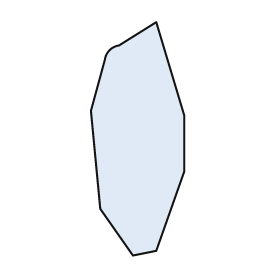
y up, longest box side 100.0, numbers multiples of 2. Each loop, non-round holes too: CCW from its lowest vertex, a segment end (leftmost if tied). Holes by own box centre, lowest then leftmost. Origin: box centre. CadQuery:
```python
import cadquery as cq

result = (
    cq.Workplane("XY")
    .moveTo(-2.0, -50.0)
    .lineTo(8.0, -48.0)
    .lineTo(20.0, -14.0)
    .lineTo(20.0, 10.0)
    .lineTo(8.0, 50.0)
    .lineTo(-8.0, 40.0)
    .threePointArc((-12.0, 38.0), (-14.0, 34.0))
    .lineTo(-20.0, 12.0)
    .lineTo(-16.0, -30.0)
    .close()
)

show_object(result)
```